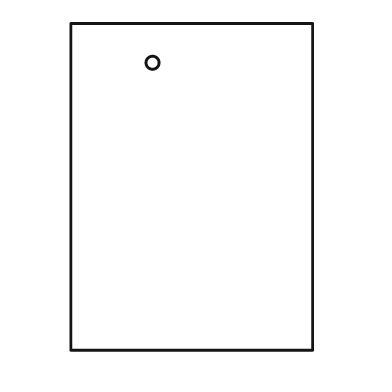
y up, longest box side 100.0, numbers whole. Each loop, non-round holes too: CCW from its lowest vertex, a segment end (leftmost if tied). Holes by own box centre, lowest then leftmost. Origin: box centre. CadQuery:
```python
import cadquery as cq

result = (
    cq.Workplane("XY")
    .moveTo(-37.0, -50.0)
    .lineTo(37.0, -50.0)
    .lineTo(37.0, 50.0)
    .lineTo(-37.0, 50.0)
    .close()
    .moveTo(-12.0, 38.0)
    .circle(2.0)
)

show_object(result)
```